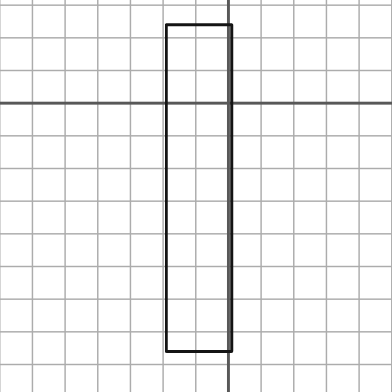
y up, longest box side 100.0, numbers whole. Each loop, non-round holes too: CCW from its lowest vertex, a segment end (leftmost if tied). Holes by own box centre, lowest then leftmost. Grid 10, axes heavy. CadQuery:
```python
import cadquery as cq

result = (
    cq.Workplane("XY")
    .moveTo(-19.0, -76.0)
    .lineTo(1.0, -76.0)
    .lineTo(1.0, 24.0)
    .lineTo(-19.0, 24.0)
    .close()
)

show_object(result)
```